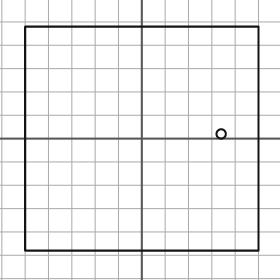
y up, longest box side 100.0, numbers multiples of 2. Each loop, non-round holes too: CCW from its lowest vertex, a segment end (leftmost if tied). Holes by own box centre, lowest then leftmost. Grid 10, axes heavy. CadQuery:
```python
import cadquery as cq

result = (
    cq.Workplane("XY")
    .moveTo(-50.0, -48.0)
    .lineTo(50.0, -48.0)
    .lineTo(50.0, 48.0)
    .lineTo(-50.0, 48.0)
    .close()
    .moveTo(34.0, 2.0)
    .circle(2.0)
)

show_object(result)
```